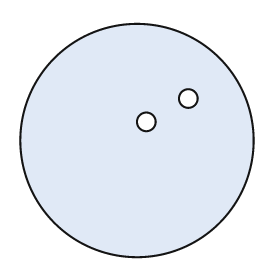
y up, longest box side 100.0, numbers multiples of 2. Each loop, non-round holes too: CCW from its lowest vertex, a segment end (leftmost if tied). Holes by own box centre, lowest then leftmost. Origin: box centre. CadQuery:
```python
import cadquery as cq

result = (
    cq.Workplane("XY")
    .moveTo(0.0, 0.0)
    .circle(50.0)
    .moveTo(4.0, 8.0)
    .circle(4.0)
    .moveTo(22.0, 18.0)
    .circle(4.0)
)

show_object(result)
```